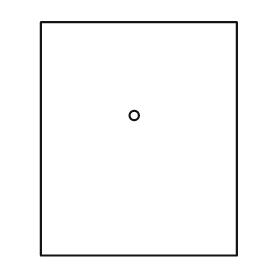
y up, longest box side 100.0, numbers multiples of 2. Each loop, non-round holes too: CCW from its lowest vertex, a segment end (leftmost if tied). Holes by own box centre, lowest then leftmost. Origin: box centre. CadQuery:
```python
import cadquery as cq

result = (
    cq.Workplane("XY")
    .moveTo(-42.0, -50.0)
    .lineTo(42.0, -50.0)
    .lineTo(42.0, 50.0)
    .lineTo(-42.0, 50.0)
    .close()
    .moveTo(-2.0, 10.0)
    .circle(2.0)
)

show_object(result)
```